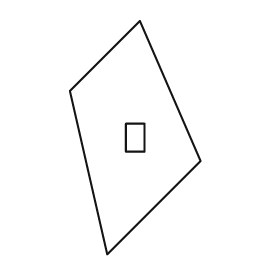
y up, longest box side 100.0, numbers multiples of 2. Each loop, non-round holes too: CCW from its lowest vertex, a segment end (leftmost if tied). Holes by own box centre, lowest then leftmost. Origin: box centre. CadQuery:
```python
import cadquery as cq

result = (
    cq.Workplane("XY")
    .moveTo(-12.0, -50.0)
    .lineTo(28.0, -10.0)
    .lineTo(2.0, 50.0)
    .lineTo(-28.0, 20.0)
    .close()
    .moveTo(-4.0, -6.0)
    .lineTo(4.0, -6.0)
    .lineTo(4.0, 6.0)
    .lineTo(-4.0, 6.0)
    .close()
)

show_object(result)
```